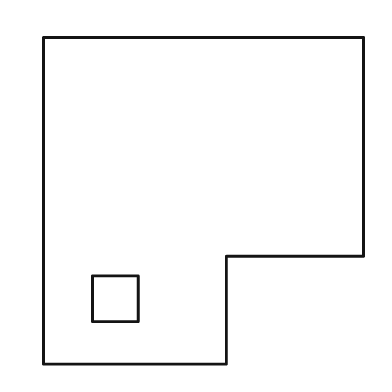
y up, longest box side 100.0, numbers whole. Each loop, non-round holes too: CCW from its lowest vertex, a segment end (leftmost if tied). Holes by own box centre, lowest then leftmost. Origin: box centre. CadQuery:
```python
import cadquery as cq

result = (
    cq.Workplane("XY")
    .moveTo(-49.0, -50.0)
    .lineTo(7.0, -50.0)
    .lineTo(7.0, -17.0)
    .lineTo(49.0, -17.0)
    .lineTo(49.0, 50.0)
    .lineTo(-49.0, 50.0)
    .close()
    .moveTo(-34.0, -37.0)
    .lineTo(-20.0, -37.0)
    .lineTo(-20.0, -23.0)
    .lineTo(-34.0, -23.0)
    .close()
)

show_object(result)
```